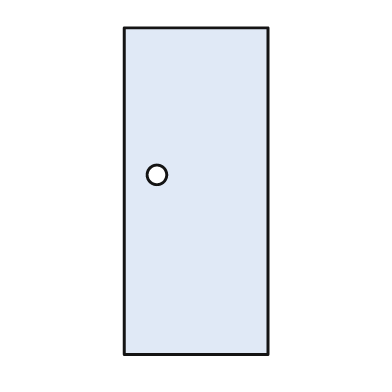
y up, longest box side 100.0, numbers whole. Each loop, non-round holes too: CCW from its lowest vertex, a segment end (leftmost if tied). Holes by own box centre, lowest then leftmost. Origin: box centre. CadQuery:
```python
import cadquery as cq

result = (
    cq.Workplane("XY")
    .moveTo(-22.0, -50.0)
    .lineTo(22.0, -50.0)
    .lineTo(22.0, 50.0)
    .lineTo(-22.0, 50.0)
    .close()
    .moveTo(-12.0, 5.0)
    .circle(3.0)
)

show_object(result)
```